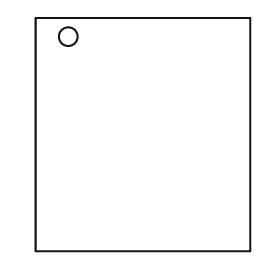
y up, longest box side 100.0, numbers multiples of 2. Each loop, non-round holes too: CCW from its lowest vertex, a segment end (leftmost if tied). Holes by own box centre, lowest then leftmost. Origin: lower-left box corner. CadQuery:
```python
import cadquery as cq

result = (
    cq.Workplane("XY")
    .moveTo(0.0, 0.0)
    .lineTo(92.0, 0.0)
    .lineTo(92.0, 100.0)
    .lineTo(0.0, 100.0)
    .close()
    .moveTo(14.0, 92.0)
    .circle(4.0)
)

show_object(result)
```